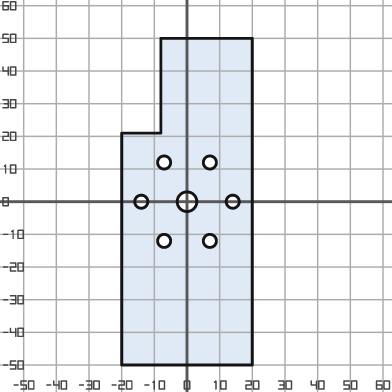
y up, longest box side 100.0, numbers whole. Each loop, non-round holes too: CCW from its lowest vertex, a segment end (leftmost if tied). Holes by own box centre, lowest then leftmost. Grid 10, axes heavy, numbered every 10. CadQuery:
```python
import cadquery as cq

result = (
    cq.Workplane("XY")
    .moveTo(-20.0, -50.0)
    .lineTo(20.0, -50.0)
    .lineTo(20.0, 50.0)
    .lineTo(-8.0, 50.0)
    .lineTo(-8.0, 21.0)
    .lineTo(-20.0, 21.0)
    .close()
    .moveTo(-7.0, -12.0)
    .circle(2.0)
    .moveTo(7.0, -12.0)
    .circle(2.0)
    .moveTo(-14.0, 0.0)
    .circle(2.0)
    .moveTo(0.0, 0.0)
    .circle(3.0)
    .moveTo(14.0, 0.0)
    .circle(2.0)
    .moveTo(-7.0, 12.0)
    .circle(2.0)
    .moveTo(7.0, 12.0)
    .circle(2.0)
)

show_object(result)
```